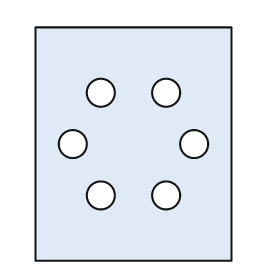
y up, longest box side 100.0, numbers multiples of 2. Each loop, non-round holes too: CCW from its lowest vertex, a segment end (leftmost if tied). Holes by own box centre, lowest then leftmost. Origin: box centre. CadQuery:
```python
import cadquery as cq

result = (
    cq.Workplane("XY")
    .moveTo(-42.0, -50.0)
    .lineTo(42.0, -50.0)
    .lineTo(42.0, 50.0)
    .lineTo(-42.0, 50.0)
    .close()
    .moveTo(-14.0, -22.0)
    .circle(6.0)
    .moveTo(14.0, -22.0)
    .circle(6.0)
    .moveTo(-26.0, 0.0)
    .circle(6.0)
    .moveTo(26.0, 0.0)
    .circle(6.0)
    .moveTo(-14.0, 22.0)
    .circle(6.0)
    .moveTo(14.0, 22.0)
    .circle(6.0)
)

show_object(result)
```